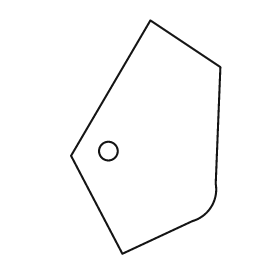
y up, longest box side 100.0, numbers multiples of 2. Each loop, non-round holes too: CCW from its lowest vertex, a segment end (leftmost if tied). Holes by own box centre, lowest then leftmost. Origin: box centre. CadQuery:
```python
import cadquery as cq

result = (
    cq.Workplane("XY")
    .moveTo(-10.0, -50.0)
    .lineTo(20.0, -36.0)
    .threePointArc((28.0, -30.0), (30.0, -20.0))
    .lineTo(32.0, 30.0)
    .lineTo(2.0, 50.0)
    .lineTo(-32.0, -8.0)
    .close()
    .moveTo(-16.0, -6.0)
    .circle(4.0)
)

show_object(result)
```